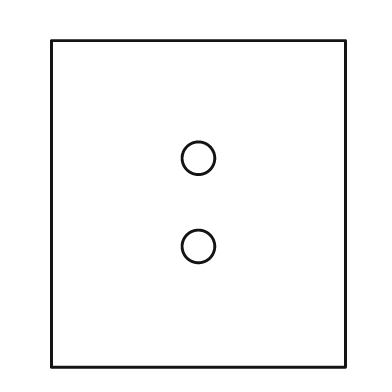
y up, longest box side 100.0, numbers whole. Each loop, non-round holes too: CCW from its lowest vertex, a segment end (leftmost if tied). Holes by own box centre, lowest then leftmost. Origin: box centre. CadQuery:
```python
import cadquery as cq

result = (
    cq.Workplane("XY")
    .moveTo(-45.0, -50.0)
    .lineTo(45.0, -50.0)
    .lineTo(45.0, 50.0)
    .lineTo(-45.0, 50.0)
    .close()
    .moveTo(0.0, -13.0)
    .circle(5.0)
    .moveTo(0.0, 14.0)
    .circle(5.0)
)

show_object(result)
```